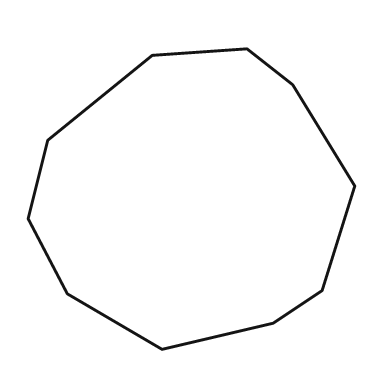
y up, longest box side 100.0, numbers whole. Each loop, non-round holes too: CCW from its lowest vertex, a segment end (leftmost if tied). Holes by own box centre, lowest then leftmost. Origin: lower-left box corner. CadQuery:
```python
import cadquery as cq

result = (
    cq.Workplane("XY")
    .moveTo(41.0, 0.0)
    .lineTo(75.0, 8.0)
    .lineTo(90.0, 18.0)
    .lineTo(100.0, 50.0)
    .lineTo(81.0, 81.0)
    .lineTo(67.0, 92.0)
    .lineTo(38.0, 90.0)
    .lineTo(6.0, 64.0)
    .lineTo(0.0, 40.0)
    .lineTo(12.0, 17.0)
    .close()
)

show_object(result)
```